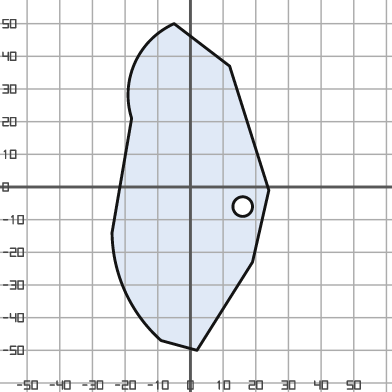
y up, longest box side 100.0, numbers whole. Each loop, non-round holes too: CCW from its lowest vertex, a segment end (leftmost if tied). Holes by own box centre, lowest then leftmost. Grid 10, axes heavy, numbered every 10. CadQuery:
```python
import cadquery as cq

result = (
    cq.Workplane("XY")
    .moveTo(2.0, -50.0)
    .lineTo(19.0, -23.0)
    .lineTo(24.0, -1.0)
    .lineTo(12.0, 37.0)
    .lineTo(-5.0, 50.0)
    .threePointArc((-17.0, 38.0), (-18.0, 21.0))
    .lineTo(-24.0, -14.0)
    .threePointArc((-20.0, -32.0), (-9.0, -47.0))
    .close()
    .moveTo(16.0, -6.0)
    .circle(3.0)
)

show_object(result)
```